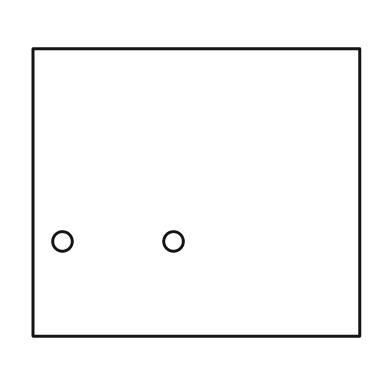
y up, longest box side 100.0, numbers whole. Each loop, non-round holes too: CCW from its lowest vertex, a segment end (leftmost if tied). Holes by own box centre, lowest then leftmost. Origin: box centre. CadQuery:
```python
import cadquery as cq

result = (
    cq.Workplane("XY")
    .moveTo(-50.0, -44.0)
    .lineTo(50.0, -44.0)
    .lineTo(50.0, 44.0)
    .lineTo(-50.0, 44.0)
    .close()
    .moveTo(-41.0, -15.0)
    .circle(3.0)
    .moveTo(-7.0, -15.0)
    .circle(3.0)
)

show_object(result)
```